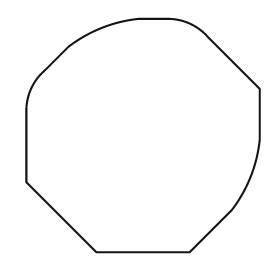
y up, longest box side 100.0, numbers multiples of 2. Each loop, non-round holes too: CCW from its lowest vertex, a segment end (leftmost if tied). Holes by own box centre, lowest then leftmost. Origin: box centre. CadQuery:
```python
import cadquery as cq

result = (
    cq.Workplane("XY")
    .moveTo(-20.0, -50.0)
    .lineTo(20.0, -50.0)
    .lineTo(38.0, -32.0)
    .threePointArc((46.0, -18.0), (50.0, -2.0))
    .lineTo(50.0, 20.0)
    .lineTo(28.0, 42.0)
    .threePointArc((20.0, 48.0), (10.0, 50.0))
    .lineTo(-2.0, 50.0)
    .threePointArc((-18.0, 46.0), (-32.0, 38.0))
    .lineTo(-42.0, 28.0)
    .threePointArc((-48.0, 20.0), (-50.0, 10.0))
    .lineTo(-50.0, -20.0)
    .close()
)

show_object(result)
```